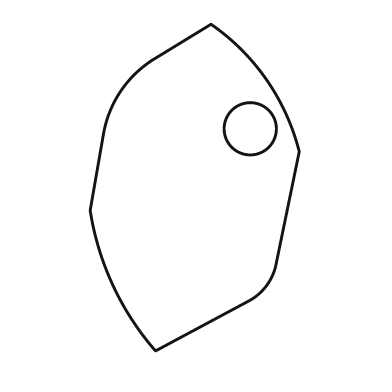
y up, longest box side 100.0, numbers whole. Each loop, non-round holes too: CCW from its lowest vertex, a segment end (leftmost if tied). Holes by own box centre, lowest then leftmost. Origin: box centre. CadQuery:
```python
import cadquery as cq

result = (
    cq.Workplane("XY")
    .moveTo(-12.0, -50.0)
    .lineTo(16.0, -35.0)
    .threePointArc((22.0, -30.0), (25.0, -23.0))
    .lineTo(32.0, 11.0)
    .threePointArc((22.0, 33.0), (5.0, 50.0))
    .lineTo(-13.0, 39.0)
    .threePointArc((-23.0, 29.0), (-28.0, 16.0))
    .lineTo(-32.0, -7.0)
    .threePointArc((-25.0, -30.0), (-12.0, -50.0))
    .close()
    .moveTo(17.0, 18.0)
    .circle(8.0)
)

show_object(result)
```